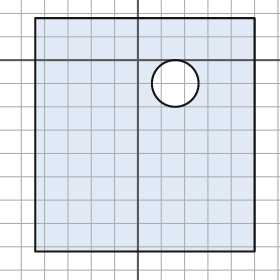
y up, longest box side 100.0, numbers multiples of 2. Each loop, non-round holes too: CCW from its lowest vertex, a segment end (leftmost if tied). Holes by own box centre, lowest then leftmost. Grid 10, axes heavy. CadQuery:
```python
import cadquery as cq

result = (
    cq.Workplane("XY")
    .moveTo(-44.0, -82.0)
    .lineTo(50.0, -82.0)
    .lineTo(50.0, 18.0)
    .lineTo(-44.0, 18.0)
    .close()
    .moveTo(16.0, -10.0)
    .circle(10.0)
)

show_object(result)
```